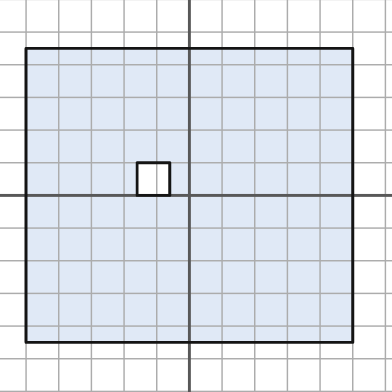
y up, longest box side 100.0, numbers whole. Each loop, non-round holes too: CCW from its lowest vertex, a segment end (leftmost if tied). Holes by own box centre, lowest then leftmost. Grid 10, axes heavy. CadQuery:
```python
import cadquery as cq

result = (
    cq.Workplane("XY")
    .moveTo(-50.0, -45.0)
    .lineTo(50.0, -45.0)
    .lineTo(50.0, 45.0)
    .lineTo(-50.0, 45.0)
    .close()
    .moveTo(-16.0, 0.0)
    .lineTo(-6.0, 0.0)
    .lineTo(-6.0, 10.0)
    .lineTo(-16.0, 10.0)
    .close()
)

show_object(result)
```